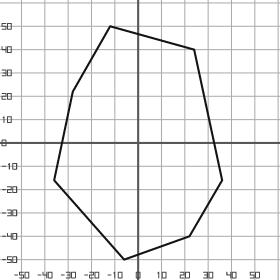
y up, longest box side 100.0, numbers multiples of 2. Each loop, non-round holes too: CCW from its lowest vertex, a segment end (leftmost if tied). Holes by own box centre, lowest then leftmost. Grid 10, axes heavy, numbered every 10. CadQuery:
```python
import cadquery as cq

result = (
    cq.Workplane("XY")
    .moveTo(-6.0, -50.0)
    .lineTo(22.0, -40.0)
    .lineTo(36.0, -16.0)
    .lineTo(24.0, 40.0)
    .lineTo(-12.0, 50.0)
    .lineTo(-28.0, 22.0)
    .lineTo(-36.0, -16.0)
    .close()
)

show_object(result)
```